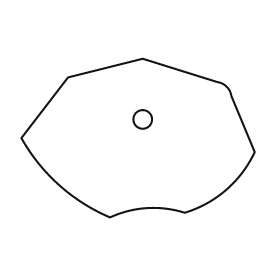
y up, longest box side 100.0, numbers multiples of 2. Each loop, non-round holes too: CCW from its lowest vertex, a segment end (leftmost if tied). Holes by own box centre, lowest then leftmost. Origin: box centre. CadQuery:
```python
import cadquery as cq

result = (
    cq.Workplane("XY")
    .moveTo(-12.0, -34.0)
    .threePointArc((4.0, -30.0), (20.0, -32.0))
    .threePointArc((38.0, -22.0), (50.0, -6.0))
    .lineTo(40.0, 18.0)
    .threePointArc((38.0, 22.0), (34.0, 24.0))
    .lineTo(2.0, 34.0)
    .lineTo(-30.0, 26.0)
    .lineTo(-50.0, 0.0)
    .threePointArc((-34.0, -20.0), (-12.0, -34.0))
    .close()
    .moveTo(2.0, 8.0)
    .circle(4.0)
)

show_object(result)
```